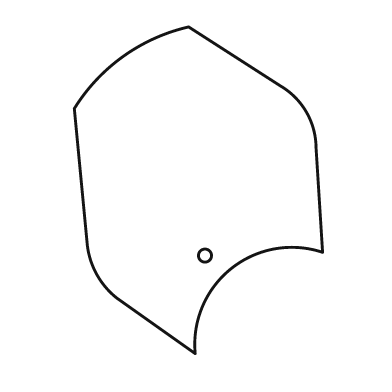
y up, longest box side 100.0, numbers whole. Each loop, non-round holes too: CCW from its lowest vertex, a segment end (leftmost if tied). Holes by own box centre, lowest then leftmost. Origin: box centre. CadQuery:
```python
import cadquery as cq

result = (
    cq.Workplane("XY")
    .moveTo(-1.0, -50.0)
    .threePointArc((10.0, -24.0), (38.0, -19.0))
    .lineTo(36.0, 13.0)
    .threePointArc((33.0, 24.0), (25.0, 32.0))
    .lineTo(-3.0, 50.0)
    .threePointArc((-23.0, 41.0), (-38.0, 25.0))
    .lineTo(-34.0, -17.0)
    .threePointArc((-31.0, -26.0), (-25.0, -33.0))
    .close()
    .moveTo(2.0, -20.0)
    .circle(2.0)
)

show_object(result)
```